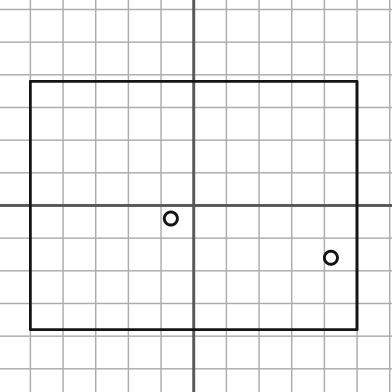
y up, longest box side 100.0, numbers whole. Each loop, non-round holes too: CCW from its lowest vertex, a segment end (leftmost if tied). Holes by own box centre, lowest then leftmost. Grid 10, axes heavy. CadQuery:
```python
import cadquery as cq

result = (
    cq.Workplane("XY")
    .moveTo(-50.0, -38.0)
    .lineTo(50.0, -38.0)
    .lineTo(50.0, 38.0)
    .lineTo(-50.0, 38.0)
    .close()
    .moveTo(42.0, -16.0)
    .circle(2.0)
    .moveTo(-7.0, -4.0)
    .circle(2.0)
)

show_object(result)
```